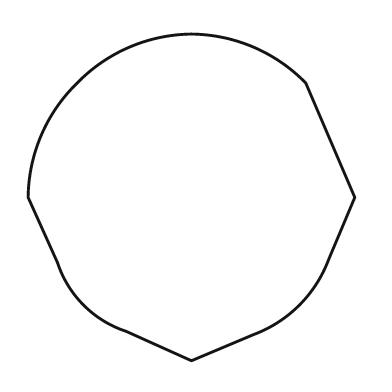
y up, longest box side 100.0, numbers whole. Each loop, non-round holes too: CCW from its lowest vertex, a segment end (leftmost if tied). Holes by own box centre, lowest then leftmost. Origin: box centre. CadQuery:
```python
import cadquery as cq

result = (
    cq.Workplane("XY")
    .moveTo(0.0, -50.0)
    .lineTo(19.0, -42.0)
    .threePointArc((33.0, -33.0), (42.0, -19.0))
    .lineTo(50.0, 0.0)
    .lineTo(35.0, 35.0)
    .threePointArc((19.0, 46.0), (0.0, 50.0))
    .threePointArc((-19.0, 46.0), (-35.0, 35.0))
    .threePointArc((-46.0, 19.0), (-50.0, 0.0))
    .lineTo(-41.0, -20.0)
    .threePointArc((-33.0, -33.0), (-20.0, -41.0))
    .close()
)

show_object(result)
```